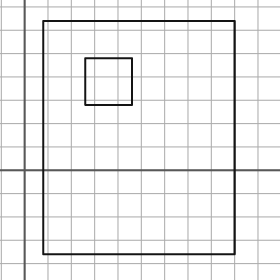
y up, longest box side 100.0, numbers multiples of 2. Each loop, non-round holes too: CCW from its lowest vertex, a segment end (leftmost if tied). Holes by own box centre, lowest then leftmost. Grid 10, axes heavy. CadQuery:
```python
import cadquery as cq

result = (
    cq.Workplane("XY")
    .moveTo(8.0, -36.0)
    .lineTo(90.0, -36.0)
    .lineTo(90.0, 64.0)
    .lineTo(8.0, 64.0)
    .close()
    .moveTo(26.0, 28.0)
    .lineTo(46.0, 28.0)
    .lineTo(46.0, 48.0)
    .lineTo(26.0, 48.0)
    .close()
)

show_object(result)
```